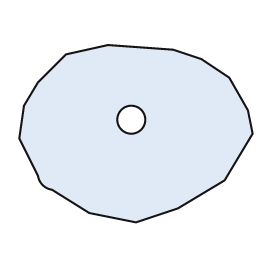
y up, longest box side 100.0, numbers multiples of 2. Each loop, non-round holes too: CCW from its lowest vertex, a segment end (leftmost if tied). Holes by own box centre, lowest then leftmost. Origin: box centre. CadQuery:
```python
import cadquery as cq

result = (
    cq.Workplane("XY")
    .moveTo(0.0, -38.0)
    .lineTo(18.0, -32.0)
    .lineTo(38.0, -20.0)
    .lineTo(50.0, 0.0)
    .lineTo(48.0, 10.0)
    .lineTo(40.0, 24.0)
    .lineTo(28.0, 32.0)
    .lineTo(16.0, 36.0)
    .lineTo(-12.0, 38.0)
    .lineTo(-30.0, 34.0)
    .lineTo(-42.0, 22.0)
    .lineTo(-48.0, 12.0)
    .lineTo(-50.0, -2.0)
    .lineTo(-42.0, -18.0)
    .threePointArc((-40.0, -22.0), (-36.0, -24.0))
    .lineTo(-20.0, -34.0)
    .close()
    .moveTo(-2.0, 6.0)
    .circle(6.0)
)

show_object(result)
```